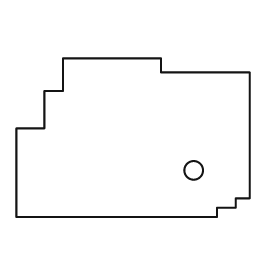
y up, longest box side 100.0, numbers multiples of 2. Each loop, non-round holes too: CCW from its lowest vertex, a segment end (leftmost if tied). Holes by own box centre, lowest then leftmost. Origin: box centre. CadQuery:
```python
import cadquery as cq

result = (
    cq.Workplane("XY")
    .moveTo(-50.0, -34.0)
    .lineTo(36.0, -34.0)
    .lineTo(36.0, -30.0)
    .lineTo(44.0, -30.0)
    .lineTo(44.0, -26.0)
    .lineTo(50.0, -26.0)
    .lineTo(50.0, 28.0)
    .lineTo(12.0, 28.0)
    .lineTo(12.0, 34.0)
    .lineTo(-30.0, 34.0)
    .lineTo(-30.0, 20.0)
    .lineTo(-38.0, 20.0)
    .lineTo(-38.0, 4.0)
    .lineTo(-50.0, 4.0)
    .close()
    .moveTo(26.0, -14.0)
    .circle(4.0)
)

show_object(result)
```